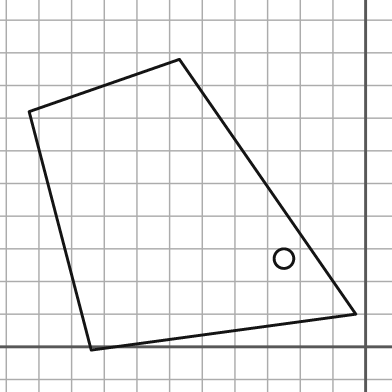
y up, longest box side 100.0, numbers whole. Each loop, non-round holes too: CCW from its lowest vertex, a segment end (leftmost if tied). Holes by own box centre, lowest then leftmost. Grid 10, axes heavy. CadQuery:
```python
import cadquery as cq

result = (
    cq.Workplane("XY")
    .moveTo(-84.0, -1.0)
    .lineTo(-3.0, 10.0)
    .lineTo(-57.0, 88.0)
    .lineTo(-103.0, 72.0)
    .close()
    .moveTo(-25.0, 27.0)
    .circle(3.0)
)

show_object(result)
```